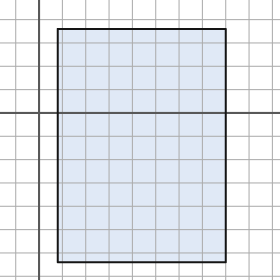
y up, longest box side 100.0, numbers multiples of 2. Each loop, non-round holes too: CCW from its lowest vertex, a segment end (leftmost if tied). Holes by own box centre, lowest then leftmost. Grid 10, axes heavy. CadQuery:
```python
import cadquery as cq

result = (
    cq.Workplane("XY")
    .moveTo(8.0, -64.0)
    .lineTo(80.0, -64.0)
    .lineTo(80.0, 36.0)
    .lineTo(8.0, 36.0)
    .close()
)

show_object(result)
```